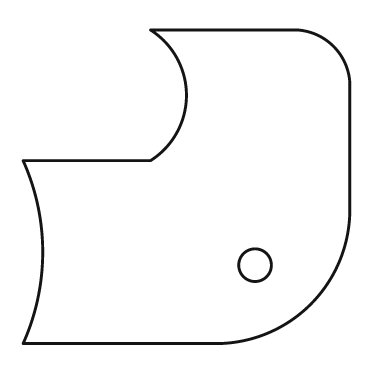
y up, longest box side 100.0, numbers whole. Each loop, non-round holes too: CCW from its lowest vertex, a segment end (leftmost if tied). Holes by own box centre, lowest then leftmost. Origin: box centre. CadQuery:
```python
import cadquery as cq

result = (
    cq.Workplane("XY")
    .moveTo(-50.0, -48.0)
    .lineTo(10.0, -48.0)
    .threePointArc((38.0, -36.0), (50.0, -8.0))
    .lineTo(50.0, 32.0)
    .threePointArc((45.0, 43.0), (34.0, 48.0))
    .lineTo(-11.0, 48.0)
    .threePointArc((0.0, 28.0), (-11.0, 8.0))
    .lineTo(-50.0, 8.0)
    .threePointArc((-44.0, -20.0), (-50.0, -48.0))
    .close()
    .moveTo(21.0, -24.0)
    .circle(5.0)
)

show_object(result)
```